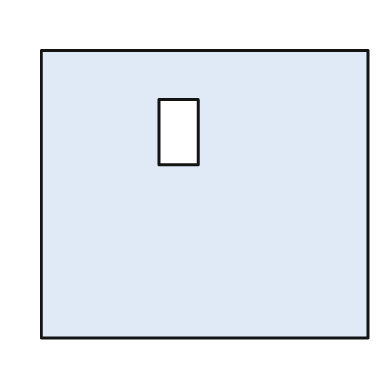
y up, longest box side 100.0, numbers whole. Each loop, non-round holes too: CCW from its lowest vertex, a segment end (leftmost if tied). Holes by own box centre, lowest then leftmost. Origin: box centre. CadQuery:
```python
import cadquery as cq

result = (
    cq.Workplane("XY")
    .moveTo(-50.0, -44.0)
    .lineTo(50.0, -44.0)
    .lineTo(50.0, 44.0)
    .lineTo(-50.0, 44.0)
    .close()
    .moveTo(-14.0, 9.0)
    .lineTo(-2.0, 9.0)
    .lineTo(-2.0, 29.0)
    .lineTo(-14.0, 29.0)
    .close()
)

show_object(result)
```